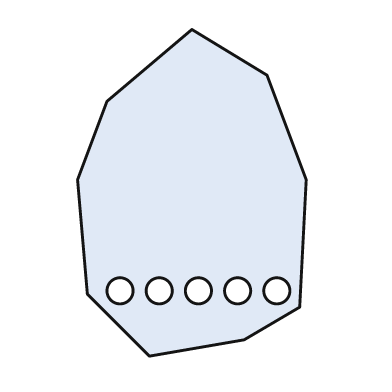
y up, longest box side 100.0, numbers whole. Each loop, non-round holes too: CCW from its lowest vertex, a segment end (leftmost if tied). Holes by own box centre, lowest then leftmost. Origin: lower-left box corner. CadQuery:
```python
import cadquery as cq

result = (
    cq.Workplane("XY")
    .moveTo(22.0, 0.0)
    .lineTo(51.0, 5.0)
    .lineTo(68.0, 15.0)
    .lineTo(70.0, 54.0)
    .lineTo(58.0, 86.0)
    .lineTo(35.0, 100.0)
    .lineTo(9.0, 78.0)
    .lineTo(0.0, 54.0)
    .lineTo(3.0, 19.0)
    .close()
    .moveTo(13.0, 20.0)
    .circle(4.0)
    .moveTo(25.0, 20.0)
    .circle(4.0)
    .moveTo(37.0, 20.0)
    .circle(4.0)
    .moveTo(49.0, 20.0)
    .circle(4.0)
    .moveTo(61.0, 20.0)
    .circle(4.0)
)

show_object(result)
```